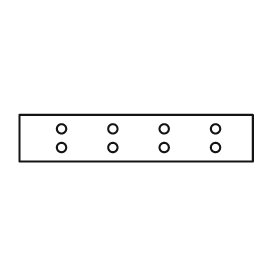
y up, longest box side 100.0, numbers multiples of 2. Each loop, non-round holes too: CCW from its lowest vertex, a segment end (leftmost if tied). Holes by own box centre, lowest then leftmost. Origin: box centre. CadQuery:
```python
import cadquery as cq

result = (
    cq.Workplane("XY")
    .moveTo(-50.0, -10.0)
    .lineTo(50.0, -10.0)
    .lineTo(50.0, 10.0)
    .lineTo(-50.0, 10.0)
    .close()
    .moveTo(-32.0, -4.0)
    .circle(2.0)
    .moveTo(-10.0, -4.0)
    .circle(2.0)
    .moveTo(12.0, -4.0)
    .circle(2.0)
    .moveTo(34.0, -4.0)
    .circle(2.0)
    .moveTo(-32.0, 4.0)
    .circle(2.0)
    .moveTo(-10.0, 4.0)
    .circle(2.0)
    .moveTo(12.0, 4.0)
    .circle(2.0)
    .moveTo(34.0, 4.0)
    .circle(2.0)
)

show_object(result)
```